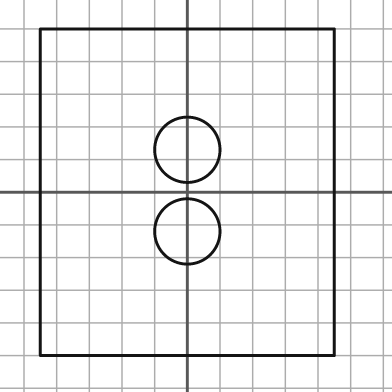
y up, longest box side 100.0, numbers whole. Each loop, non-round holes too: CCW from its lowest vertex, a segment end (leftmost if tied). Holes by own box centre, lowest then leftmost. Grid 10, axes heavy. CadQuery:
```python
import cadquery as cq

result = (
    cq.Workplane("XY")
    .moveTo(-45.0, -50.0)
    .lineTo(45.0, -50.0)
    .lineTo(45.0, 50.0)
    .lineTo(-45.0, 50.0)
    .close()
    .moveTo(0.0, -12.0)
    .circle(10.0)
    .moveTo(0.0, 13.0)
    .circle(10.0)
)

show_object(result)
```